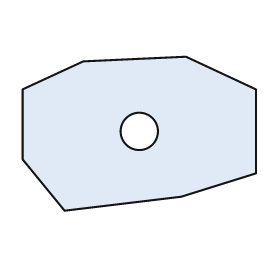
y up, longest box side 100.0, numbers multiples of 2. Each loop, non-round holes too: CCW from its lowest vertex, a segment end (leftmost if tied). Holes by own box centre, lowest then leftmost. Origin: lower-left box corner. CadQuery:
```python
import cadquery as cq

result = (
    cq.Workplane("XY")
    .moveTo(18.0, 0.0)
    .lineTo(68.0, 6.0)
    .lineTo(100.0, 16.0)
    .lineTo(100.0, 52.0)
    .lineTo(70.0, 66.0)
    .lineTo(26.0, 64.0)
    .lineTo(0.0, 52.0)
    .lineTo(0.0, 22.0)
    .close()
    .moveTo(50.0, 34.0)
    .circle(8.0)
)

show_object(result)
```